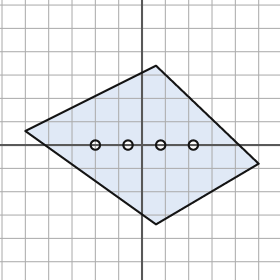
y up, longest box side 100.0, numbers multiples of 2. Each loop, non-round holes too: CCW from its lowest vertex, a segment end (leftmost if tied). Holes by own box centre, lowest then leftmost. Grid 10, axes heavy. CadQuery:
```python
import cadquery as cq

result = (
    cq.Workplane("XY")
    .moveTo(6.0, -34.0)
    .lineTo(50.0, -8.0)
    .lineTo(6.0, 34.0)
    .lineTo(-50.0, 6.0)
    .close()
    .moveTo(-20.0, 0.0)
    .circle(2.0)
    .moveTo(-6.0, 0.0)
    .circle(2.0)
    .moveTo(8.0, 0.0)
    .circle(2.0)
    .moveTo(22.0, 0.0)
    .circle(2.0)
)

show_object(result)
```